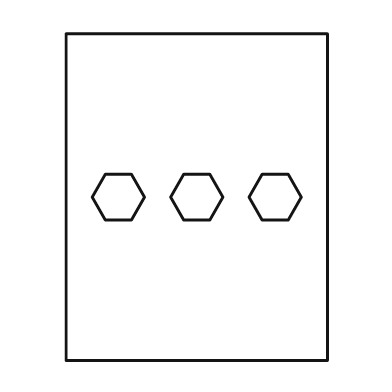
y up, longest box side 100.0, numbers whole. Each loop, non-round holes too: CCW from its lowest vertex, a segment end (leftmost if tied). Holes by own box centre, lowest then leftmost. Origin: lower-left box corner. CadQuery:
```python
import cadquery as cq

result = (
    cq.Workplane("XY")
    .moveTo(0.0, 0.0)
    .lineTo(80.0, 0.0)
    .lineTo(80.0, 100.0)
    .lineTo(0.0, 100.0)
    .close()
    .moveTo(12.0, 43.0)
    .lineTo(20.0, 43.0)
    .lineTo(24.0, 50.0)
    .lineTo(20.0, 57.0)
    .lineTo(12.0, 57.0)
    .lineTo(8.0, 50.0)
    .close()
    .moveTo(36.0, 43.0)
    .lineTo(44.0, 43.0)
    .lineTo(48.0, 50.0)
    .lineTo(44.0, 57.0)
    .lineTo(36.0, 57.0)
    .lineTo(32.0, 50.0)
    .close()
    .moveTo(60.0, 43.0)
    .lineTo(68.0, 43.0)
    .lineTo(72.0, 50.0)
    .lineTo(68.0, 57.0)
    .lineTo(60.0, 57.0)
    .lineTo(56.0, 50.0)
    .close()
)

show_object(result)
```